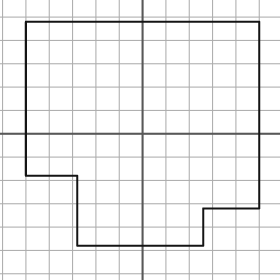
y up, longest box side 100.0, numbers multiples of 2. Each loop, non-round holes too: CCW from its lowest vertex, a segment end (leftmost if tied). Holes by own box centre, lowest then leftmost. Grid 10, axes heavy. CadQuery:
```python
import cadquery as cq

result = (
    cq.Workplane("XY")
    .moveTo(-28.0, -48.0)
    .lineTo(26.0, -48.0)
    .lineTo(26.0, -32.0)
    .lineTo(50.0, -32.0)
    .lineTo(50.0, 48.0)
    .lineTo(-50.0, 48.0)
    .lineTo(-50.0, -18.0)
    .lineTo(-28.0, -18.0)
    .close()
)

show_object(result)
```